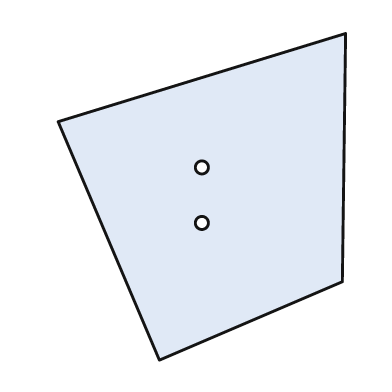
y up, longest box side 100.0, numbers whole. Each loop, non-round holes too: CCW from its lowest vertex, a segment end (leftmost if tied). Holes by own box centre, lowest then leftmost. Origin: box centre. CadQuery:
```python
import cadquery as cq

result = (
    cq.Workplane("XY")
    .moveTo(-13.0, -50.0)
    .lineTo(43.0, -26.0)
    .lineTo(44.0, 50.0)
    .lineTo(-44.0, 23.0)
    .close()
    .moveTo(0.0, -8.0)
    .circle(2.0)
    .moveTo(0.0, 9.0)
    .circle(2.0)
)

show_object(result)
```